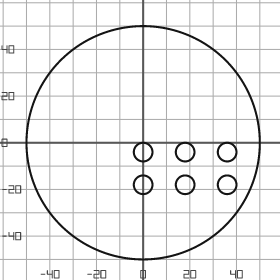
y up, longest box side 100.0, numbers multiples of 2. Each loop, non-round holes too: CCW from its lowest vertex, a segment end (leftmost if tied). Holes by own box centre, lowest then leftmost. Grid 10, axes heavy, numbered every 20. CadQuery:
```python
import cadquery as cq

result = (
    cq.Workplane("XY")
    .moveTo(0.0, 0.0)
    .circle(50.0)
    .moveTo(0.0, -18.0)
    .circle(4.0)
    .moveTo(18.0, -18.0)
    .circle(4.0)
    .moveTo(36.0, -18.0)
    .circle(4.0)
    .moveTo(0.0, -4.0)
    .circle(4.0)
    .moveTo(18.0, -4.0)
    .circle(4.0)
    .moveTo(36.0, -4.0)
    .circle(4.0)
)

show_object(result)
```